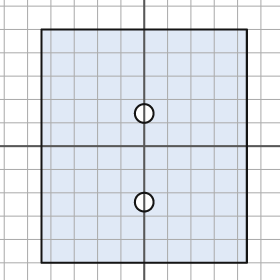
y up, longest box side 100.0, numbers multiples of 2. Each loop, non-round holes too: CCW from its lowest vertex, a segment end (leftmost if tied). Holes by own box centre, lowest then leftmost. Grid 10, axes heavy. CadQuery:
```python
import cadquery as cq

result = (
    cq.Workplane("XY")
    .moveTo(-44.0, -50.0)
    .lineTo(44.0, -50.0)
    .lineTo(44.0, 50.0)
    .lineTo(-44.0, 50.0)
    .close()
    .moveTo(0.0, -24.0)
    .circle(4.0)
    .moveTo(0.0, 14.0)
    .circle(4.0)
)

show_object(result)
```